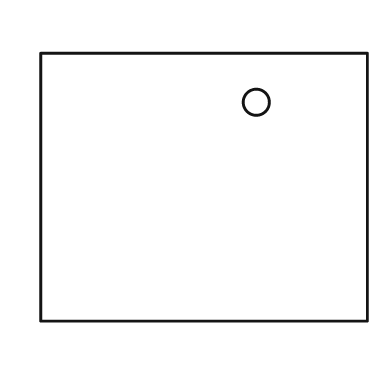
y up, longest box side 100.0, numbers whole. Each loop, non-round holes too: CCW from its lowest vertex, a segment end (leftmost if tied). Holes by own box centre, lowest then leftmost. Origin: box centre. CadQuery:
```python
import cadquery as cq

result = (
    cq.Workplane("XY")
    .moveTo(-50.0, -41.0)
    .lineTo(50.0, -41.0)
    .lineTo(50.0, 41.0)
    .lineTo(-50.0, 41.0)
    .close()
    .moveTo(16.0, 26.0)
    .circle(4.0)
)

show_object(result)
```